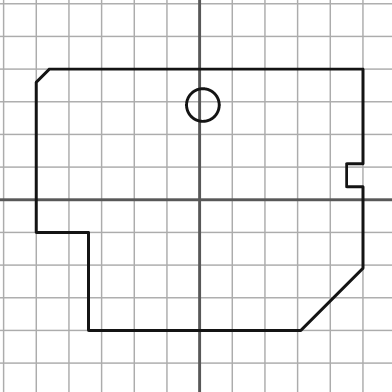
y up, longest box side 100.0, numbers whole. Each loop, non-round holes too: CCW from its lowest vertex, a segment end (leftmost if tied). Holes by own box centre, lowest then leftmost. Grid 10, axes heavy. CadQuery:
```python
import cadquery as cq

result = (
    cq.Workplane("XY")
    .moveTo(-34.0, -40.0)
    .lineTo(31.0, -40.0)
    .lineTo(50.0, -21.0)
    .lineTo(50.0, 4.0)
    .lineTo(45.0, 4.0)
    .lineTo(45.0, 11.0)
    .lineTo(50.0, 11.0)
    .lineTo(50.0, 40.0)
    .lineTo(-46.0, 40.0)
    .lineTo(-50.0, 36.0)
    .lineTo(-50.0, -10.0)
    .lineTo(-34.0, -10.0)
    .close()
    .moveTo(1.0, 29.0)
    .circle(5.0)
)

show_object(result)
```